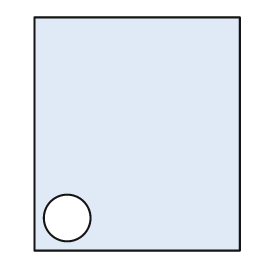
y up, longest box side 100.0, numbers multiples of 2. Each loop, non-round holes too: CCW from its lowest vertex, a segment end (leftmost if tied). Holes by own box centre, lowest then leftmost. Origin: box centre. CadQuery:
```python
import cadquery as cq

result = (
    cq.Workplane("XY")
    .moveTo(-44.0, -50.0)
    .lineTo(44.0, -50.0)
    .lineTo(44.0, 50.0)
    .lineTo(-44.0, 50.0)
    .close()
    .moveTo(-30.0, -36.0)
    .circle(10.0)
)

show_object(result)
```